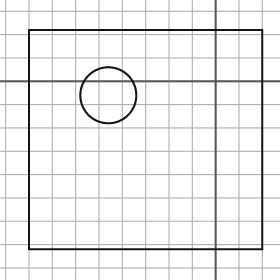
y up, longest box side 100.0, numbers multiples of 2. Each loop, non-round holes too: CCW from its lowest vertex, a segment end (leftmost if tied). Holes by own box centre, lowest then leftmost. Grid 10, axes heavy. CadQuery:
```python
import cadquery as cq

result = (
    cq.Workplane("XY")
    .moveTo(-80.0, -72.0)
    .lineTo(20.0, -72.0)
    .lineTo(20.0, 22.0)
    .lineTo(-80.0, 22.0)
    .close()
    .moveTo(-46.0, -6.0)
    .circle(12.0)
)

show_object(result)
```